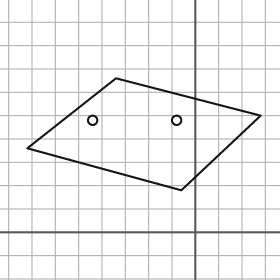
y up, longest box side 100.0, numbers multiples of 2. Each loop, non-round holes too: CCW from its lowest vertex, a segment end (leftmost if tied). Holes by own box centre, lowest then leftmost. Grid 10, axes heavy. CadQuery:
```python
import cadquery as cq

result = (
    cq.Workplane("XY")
    .moveTo(-6.0, 18.0)
    .lineTo(28.0, 50.0)
    .lineTo(-34.0, 66.0)
    .lineTo(-72.0, 36.0)
    .close()
    .moveTo(-44.0, 48.0)
    .circle(2.0)
    .moveTo(-8.0, 48.0)
    .circle(2.0)
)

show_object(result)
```